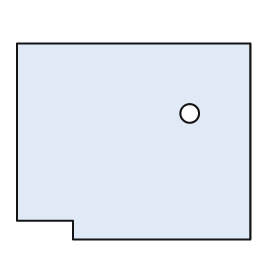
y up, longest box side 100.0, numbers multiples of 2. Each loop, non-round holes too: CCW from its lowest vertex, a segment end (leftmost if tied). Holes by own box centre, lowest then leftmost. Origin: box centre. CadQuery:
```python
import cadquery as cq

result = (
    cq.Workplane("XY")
    .moveTo(-26.0, -42.0)
    .lineTo(50.0, -42.0)
    .lineTo(50.0, 42.0)
    .lineTo(-50.0, 42.0)
    .lineTo(-50.0, -34.0)
    .lineTo(-26.0, -34.0)
    .close()
    .moveTo(24.0, 12.0)
    .circle(4.0)
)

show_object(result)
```